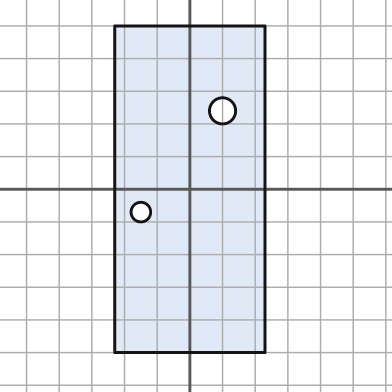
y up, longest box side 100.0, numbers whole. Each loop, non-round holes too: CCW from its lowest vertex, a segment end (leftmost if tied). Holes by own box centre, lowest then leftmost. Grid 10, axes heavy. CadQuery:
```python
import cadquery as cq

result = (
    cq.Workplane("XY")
    .moveTo(-23.0, -50.0)
    .lineTo(23.0, -50.0)
    .lineTo(23.0, 50.0)
    .lineTo(-23.0, 50.0)
    .close()
    .moveTo(-15.0, -7.0)
    .circle(3.0)
    .moveTo(10.0, 24.0)
    .circle(4.0)
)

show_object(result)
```